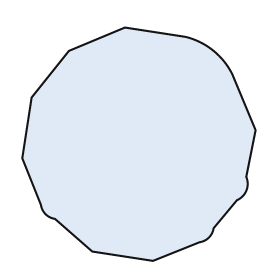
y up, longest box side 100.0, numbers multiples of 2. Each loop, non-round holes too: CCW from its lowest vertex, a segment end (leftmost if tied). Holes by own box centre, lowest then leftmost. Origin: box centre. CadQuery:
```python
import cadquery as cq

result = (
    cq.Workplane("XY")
    .moveTo(6.0, -50.0)
    .lineTo(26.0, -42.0)
    .threePointArc((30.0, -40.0), (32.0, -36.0))
    .lineTo(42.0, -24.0)
    .threePointArc((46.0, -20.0), (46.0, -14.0))
    .lineTo(50.0, 6.0)
    .lineTo(40.0, 30.0)
    .threePointArc((32.0, 40.0), (20.0, 46.0))
    .lineTo(-6.0, 50.0)
    .lineTo(-30.0, 40.0)
    .lineTo(-46.0, 20.0)
    .lineTo(-50.0, -6.0)
    .lineTo(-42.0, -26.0)
    .threePointArc((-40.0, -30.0), (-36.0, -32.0))
    .lineTo(-20.0, -46.0)
    .close()
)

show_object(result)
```